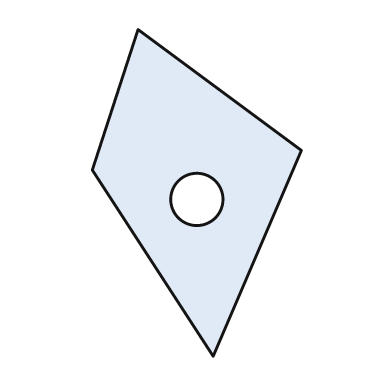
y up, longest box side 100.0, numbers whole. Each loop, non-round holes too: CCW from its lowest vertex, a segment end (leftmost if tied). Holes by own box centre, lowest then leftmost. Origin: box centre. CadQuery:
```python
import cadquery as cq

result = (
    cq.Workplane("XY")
    .moveTo(5.0, -50.0)
    .lineTo(32.0, 13.0)
    .lineTo(-18.0, 50.0)
    .lineTo(-32.0, 7.0)
    .close()
    .moveTo(0.0, -2.0)
    .circle(8.0)
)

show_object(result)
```